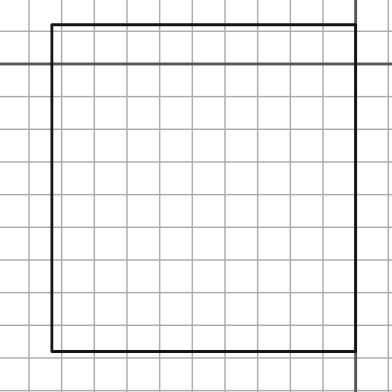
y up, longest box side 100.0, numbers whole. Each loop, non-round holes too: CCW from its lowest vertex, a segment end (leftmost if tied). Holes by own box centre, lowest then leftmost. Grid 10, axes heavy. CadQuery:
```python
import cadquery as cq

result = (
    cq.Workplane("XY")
    .moveTo(-93.0, -88.0)
    .lineTo(0.0, -88.0)
    .lineTo(0.0, 12.0)
    .lineTo(-93.0, 12.0)
    .close()
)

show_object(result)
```